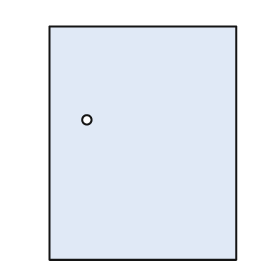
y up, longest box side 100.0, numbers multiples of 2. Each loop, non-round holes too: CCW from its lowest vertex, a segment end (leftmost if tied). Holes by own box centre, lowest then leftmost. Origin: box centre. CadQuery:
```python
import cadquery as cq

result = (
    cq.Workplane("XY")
    .moveTo(-40.0, -50.0)
    .lineTo(40.0, -50.0)
    .lineTo(40.0, 50.0)
    .lineTo(-40.0, 50.0)
    .close()
    .moveTo(-24.0, 10.0)
    .circle(2.0)
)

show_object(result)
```